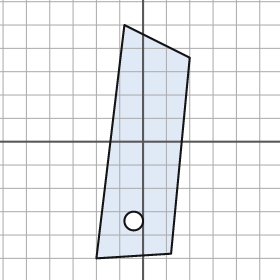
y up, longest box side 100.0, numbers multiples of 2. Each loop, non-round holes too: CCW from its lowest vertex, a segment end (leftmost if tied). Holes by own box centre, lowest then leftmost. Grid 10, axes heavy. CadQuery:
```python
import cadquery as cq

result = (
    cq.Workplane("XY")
    .moveTo(-20.0, -50.0)
    .lineTo(12.0, -48.0)
    .lineTo(20.0, 36.0)
    .lineTo(-8.0, 50.0)
    .close()
    .moveTo(-4.0, -34.0)
    .circle(4.0)
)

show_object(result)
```